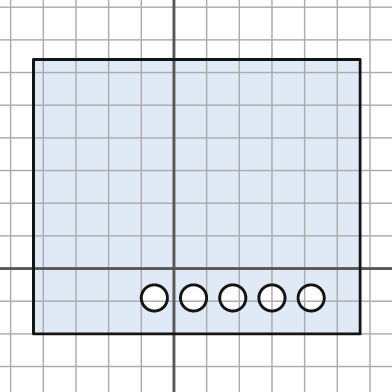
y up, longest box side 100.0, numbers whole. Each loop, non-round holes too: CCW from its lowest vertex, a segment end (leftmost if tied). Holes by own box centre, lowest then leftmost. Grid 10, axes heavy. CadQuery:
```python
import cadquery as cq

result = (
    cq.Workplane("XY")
    .moveTo(-43.0, -20.0)
    .lineTo(57.0, -20.0)
    .lineTo(57.0, 64.0)
    .lineTo(-43.0, 64.0)
    .close()
    .moveTo(-6.0, -9.0)
    .circle(4.0)
    .moveTo(6.0, -9.0)
    .circle(4.0)
    .moveTo(18.0, -9.0)
    .circle(4.0)
    .moveTo(30.0, -9.0)
    .circle(4.0)
    .moveTo(42.0, -9.0)
    .circle(4.0)
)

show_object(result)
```